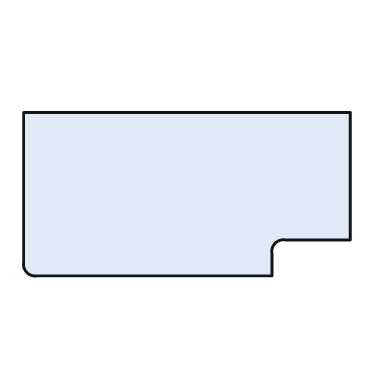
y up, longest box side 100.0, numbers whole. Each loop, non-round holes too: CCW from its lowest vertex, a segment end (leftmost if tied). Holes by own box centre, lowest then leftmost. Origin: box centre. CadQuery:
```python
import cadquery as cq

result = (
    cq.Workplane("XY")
    .moveTo(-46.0, -25.0)
    .lineTo(26.0, -25.0)
    .lineTo(26.0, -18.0)
    .threePointArc((27.0, -15.0), (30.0, -14.0))
    .lineTo(50.0, -14.0)
    .lineTo(50.0, 25.0)
    .lineTo(-50.0, 25.0)
    .lineTo(-50.0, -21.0)
    .threePointArc((-49.0, -24.0), (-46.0, -25.0))
    .close()
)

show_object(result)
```